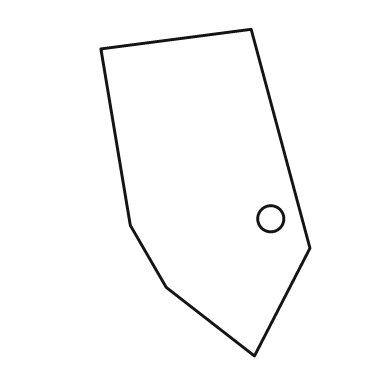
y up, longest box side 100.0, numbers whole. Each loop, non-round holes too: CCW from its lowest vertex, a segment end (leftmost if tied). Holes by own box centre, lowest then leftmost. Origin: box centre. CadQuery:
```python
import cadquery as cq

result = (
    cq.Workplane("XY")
    .moveTo(15.0, -50.0)
    .lineTo(32.0, -17.0)
    .lineTo(14.0, 50.0)
    .lineTo(-32.0, 44.0)
    .lineTo(-23.0, -10.0)
    .lineTo(-12.0, -29.0)
    .close()
    .moveTo(20.0, -8.0)
    .circle(4.0)
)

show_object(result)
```